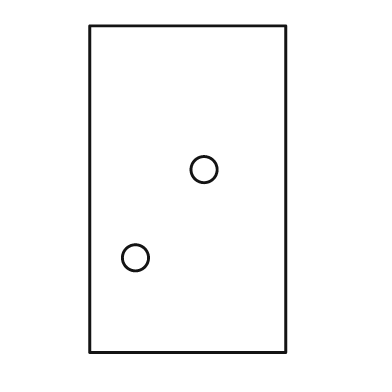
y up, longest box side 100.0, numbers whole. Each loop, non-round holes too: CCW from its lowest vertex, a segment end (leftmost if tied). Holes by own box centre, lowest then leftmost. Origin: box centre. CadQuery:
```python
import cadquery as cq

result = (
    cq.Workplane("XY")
    .moveTo(-30.0, -50.0)
    .lineTo(30.0, -50.0)
    .lineTo(30.0, 50.0)
    .lineTo(-30.0, 50.0)
    .close()
    .moveTo(-16.0, -21.0)
    .circle(4.0)
    .moveTo(5.0, 6.0)
    .circle(4.0)
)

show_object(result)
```